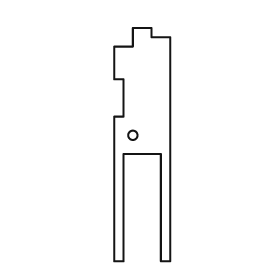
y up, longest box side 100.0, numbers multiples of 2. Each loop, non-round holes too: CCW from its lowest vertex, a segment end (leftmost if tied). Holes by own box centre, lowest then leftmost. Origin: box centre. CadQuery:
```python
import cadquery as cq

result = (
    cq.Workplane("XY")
    .moveTo(-12.0, -50.0)
    .lineTo(-8.0, -50.0)
    .lineTo(-8.0, -4.0)
    .lineTo(8.0, -4.0)
    .lineTo(8.0, -50.0)
    .lineTo(12.0, -50.0)
    .lineTo(12.0, 46.0)
    .lineTo(4.0, 46.0)
    .lineTo(4.0, 50.0)
    .lineTo(-4.0, 50.0)
    .lineTo(-4.0, 42.0)
    .lineTo(-12.0, 42.0)
    .lineTo(-12.0, 28.0)
    .lineTo(-8.0, 28.0)
    .lineTo(-8.0, 12.0)
    .lineTo(-12.0, 12.0)
    .close()
    .moveTo(-4.0, 4.0)
    .circle(2.0)
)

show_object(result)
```